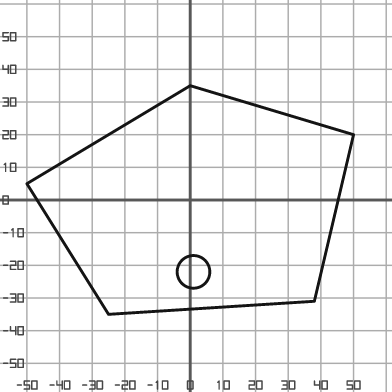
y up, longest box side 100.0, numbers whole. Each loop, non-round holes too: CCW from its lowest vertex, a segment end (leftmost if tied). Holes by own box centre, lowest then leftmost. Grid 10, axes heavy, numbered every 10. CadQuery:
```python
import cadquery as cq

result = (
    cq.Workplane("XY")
    .moveTo(-25.0, -35.0)
    .lineTo(38.0, -31.0)
    .lineTo(50.0, 20.0)
    .lineTo(0.0, 35.0)
    .lineTo(-50.0, 5.0)
    .close()
    .moveTo(1.0, -22.0)
    .circle(5.0)
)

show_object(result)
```